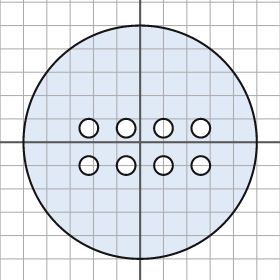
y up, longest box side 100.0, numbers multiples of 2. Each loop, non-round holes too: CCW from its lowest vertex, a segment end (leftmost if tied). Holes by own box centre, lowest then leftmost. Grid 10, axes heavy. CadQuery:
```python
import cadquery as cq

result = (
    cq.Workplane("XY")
    .moveTo(0.0, 0.0)
    .circle(50.0)
    .moveTo(-22.0, -10.0)
    .circle(4.0)
    .moveTo(-6.0, -10.0)
    .circle(4.0)
    .moveTo(10.0, -10.0)
    .circle(4.0)
    .moveTo(26.0, -10.0)
    .circle(4.0)
    .moveTo(-22.0, 6.0)
    .circle(4.0)
    .moveTo(-6.0, 6.0)
    .circle(4.0)
    .moveTo(10.0, 6.0)
    .circle(4.0)
    .moveTo(26.0, 6.0)
    .circle(4.0)
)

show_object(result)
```